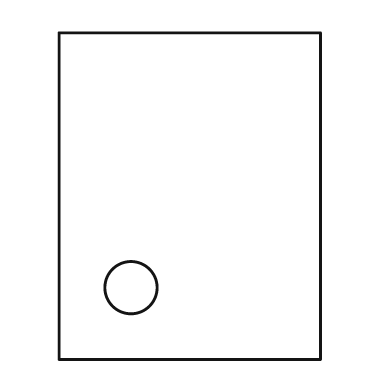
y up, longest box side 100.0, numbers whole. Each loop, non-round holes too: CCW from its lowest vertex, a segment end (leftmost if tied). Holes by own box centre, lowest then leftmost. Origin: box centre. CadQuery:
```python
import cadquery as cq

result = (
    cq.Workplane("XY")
    .moveTo(-40.0, -50.0)
    .lineTo(40.0, -50.0)
    .lineTo(40.0, 50.0)
    .lineTo(-40.0, 50.0)
    .close()
    .moveTo(-18.0, -28.0)
    .circle(8.0)
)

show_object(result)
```